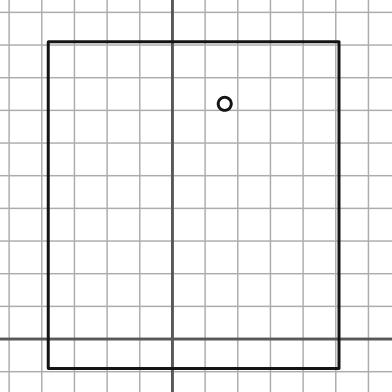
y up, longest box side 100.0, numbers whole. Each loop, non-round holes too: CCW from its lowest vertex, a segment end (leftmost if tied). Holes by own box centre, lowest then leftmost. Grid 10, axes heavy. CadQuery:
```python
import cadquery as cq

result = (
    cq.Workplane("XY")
    .moveTo(-38.0, -9.0)
    .lineTo(51.0, -9.0)
    .lineTo(51.0, 91.0)
    .lineTo(-38.0, 91.0)
    .close()
    .moveTo(16.0, 72.0)
    .circle(2.0)
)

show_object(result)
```